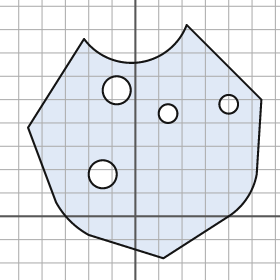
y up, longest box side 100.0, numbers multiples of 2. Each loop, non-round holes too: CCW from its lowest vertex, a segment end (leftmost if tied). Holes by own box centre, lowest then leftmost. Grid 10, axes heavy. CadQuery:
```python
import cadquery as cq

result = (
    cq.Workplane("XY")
    .moveTo(12.0, -18.0)
    .lineTo(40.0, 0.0)
    .threePointArc((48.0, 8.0), (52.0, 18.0))
    .lineTo(54.0, 50.0)
    .lineTo(22.0, 82.0)
    .threePointArc((2.0, 66.0), (-22.0, 76.0))
    .lineTo(-46.0, 38.0)
    .lineTo(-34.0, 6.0)
    .threePointArc((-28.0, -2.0), (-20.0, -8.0))
    .close()
    .moveTo(-14.0, 18.0)
    .circle(6.0)
    .moveTo(14.0, 44.0)
    .circle(4.0)
    .moveTo(40.0, 48.0)
    .circle(4.0)
    .moveTo(-8.0, 54.0)
    .circle(6.0)
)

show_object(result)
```